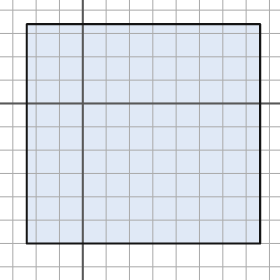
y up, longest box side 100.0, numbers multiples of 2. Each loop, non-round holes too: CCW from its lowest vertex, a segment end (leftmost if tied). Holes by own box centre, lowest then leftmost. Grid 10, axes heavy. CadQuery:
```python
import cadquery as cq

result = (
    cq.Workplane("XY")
    .moveTo(-24.0, -60.0)
    .lineTo(76.0, -60.0)
    .lineTo(76.0, 34.0)
    .lineTo(-24.0, 34.0)
    .close()
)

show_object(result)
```